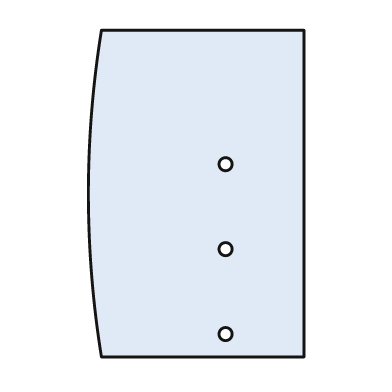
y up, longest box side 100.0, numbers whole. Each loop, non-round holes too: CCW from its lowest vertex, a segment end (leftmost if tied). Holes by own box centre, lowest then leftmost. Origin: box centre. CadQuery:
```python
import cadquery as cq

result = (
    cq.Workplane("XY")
    .moveTo(-29.0, -50.0)
    .lineTo(33.0, -50.0)
    .lineTo(33.0, 50.0)
    .lineTo(-29.0, 50.0)
    .threePointArc((-33.0, 0.0), (-29.0, -50.0))
    .close()
    .moveTo(9.0, -43.0)
    .circle(2.0)
    .moveTo(9.0, -17.0)
    .circle(2.0)
    .moveTo(9.0, 9.0)
    .circle(2.0)
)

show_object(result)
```